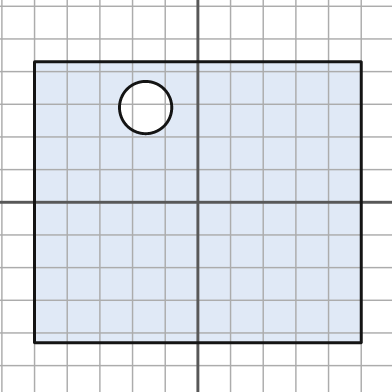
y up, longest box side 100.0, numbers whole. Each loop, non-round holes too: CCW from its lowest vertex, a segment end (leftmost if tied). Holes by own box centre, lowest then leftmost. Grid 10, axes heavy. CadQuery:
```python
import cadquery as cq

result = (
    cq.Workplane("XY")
    .moveTo(-50.0, -43.0)
    .lineTo(50.0, -43.0)
    .lineTo(50.0, 43.0)
    .lineTo(-50.0, 43.0)
    .close()
    .moveTo(-16.0, 29.0)
    .circle(8.0)
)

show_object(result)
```